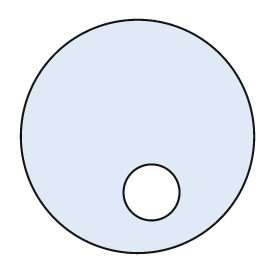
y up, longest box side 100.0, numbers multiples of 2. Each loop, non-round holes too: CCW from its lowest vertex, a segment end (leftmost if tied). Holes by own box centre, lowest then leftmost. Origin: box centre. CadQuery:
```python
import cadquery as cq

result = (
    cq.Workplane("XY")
    .moveTo(0.0, 0.0)
    .circle(50.0)
    .moveTo(6.0, -24.0)
    .circle(12.0)
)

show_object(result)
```